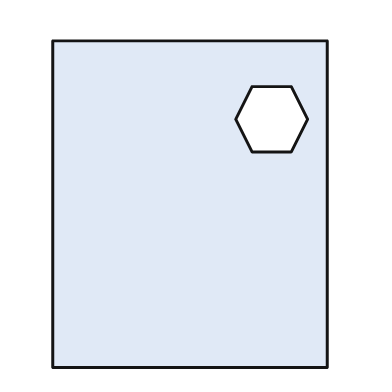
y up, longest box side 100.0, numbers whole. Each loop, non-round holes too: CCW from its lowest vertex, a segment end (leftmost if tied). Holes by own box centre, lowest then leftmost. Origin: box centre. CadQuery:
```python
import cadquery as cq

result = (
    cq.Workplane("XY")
    .moveTo(-42.0, -50.0)
    .lineTo(42.0, -50.0)
    .lineTo(42.0, 50.0)
    .lineTo(-42.0, 50.0)
    .close()
    .moveTo(19.0, 16.0)
    .lineTo(31.0, 16.0)
    .lineTo(36.0, 26.0)
    .lineTo(31.0, 36.0)
    .lineTo(19.0, 36.0)
    .lineTo(14.0, 26.0)
    .close()
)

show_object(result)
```